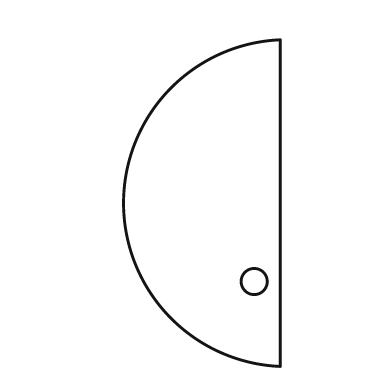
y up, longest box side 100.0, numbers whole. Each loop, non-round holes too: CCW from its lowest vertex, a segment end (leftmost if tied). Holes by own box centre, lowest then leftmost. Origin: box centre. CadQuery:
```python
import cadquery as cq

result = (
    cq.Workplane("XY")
    .moveTo(24.0, -50.0)
    .lineTo(24.0, 50.0)
    .threePointArc((-24.0, 0.0), (24.0, -50.0))
    .close()
    .moveTo(16.0, -24.0)
    .circle(4.0)
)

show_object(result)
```